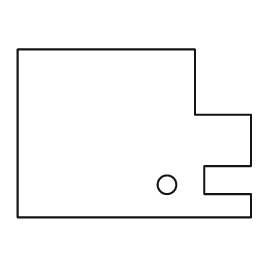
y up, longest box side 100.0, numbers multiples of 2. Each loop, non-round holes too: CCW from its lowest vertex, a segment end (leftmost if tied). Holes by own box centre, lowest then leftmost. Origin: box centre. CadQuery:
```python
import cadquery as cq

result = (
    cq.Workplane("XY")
    .moveTo(-50.0, -36.0)
    .lineTo(50.0, -36.0)
    .lineTo(50.0, -26.0)
    .lineTo(30.0, -26.0)
    .lineTo(30.0, -14.0)
    .lineTo(50.0, -14.0)
    .lineTo(50.0, 8.0)
    .lineTo(26.0, 8.0)
    .lineTo(26.0, 36.0)
    .lineTo(-50.0, 36.0)
    .close()
    .moveTo(14.0, -22.0)
    .circle(4.0)
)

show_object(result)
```